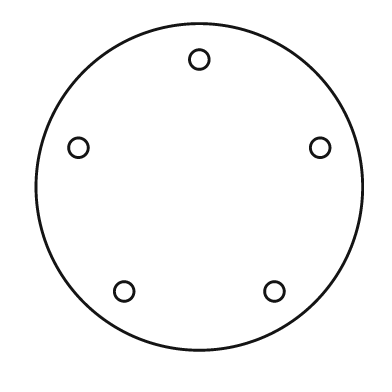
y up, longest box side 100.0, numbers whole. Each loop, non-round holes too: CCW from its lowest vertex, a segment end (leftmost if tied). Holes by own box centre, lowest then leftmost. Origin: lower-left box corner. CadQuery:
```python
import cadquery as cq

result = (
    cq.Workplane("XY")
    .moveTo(50.0, 50.0)
    .circle(50.0)
    .moveTo(27.0, 18.0)
    .circle(3.0)
    .moveTo(73.0, 18.0)
    .circle(3.0)
    .moveTo(13.0, 62.0)
    .circle(3.0)
    .moveTo(87.0, 62.0)
    .circle(3.0)
    .moveTo(50.0, 89.0)
    .circle(3.0)
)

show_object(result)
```